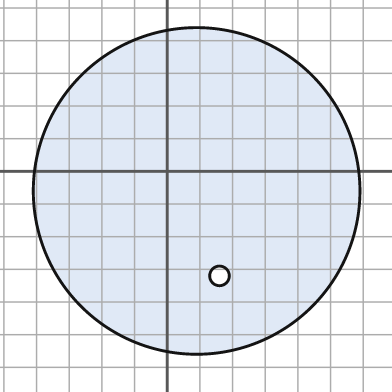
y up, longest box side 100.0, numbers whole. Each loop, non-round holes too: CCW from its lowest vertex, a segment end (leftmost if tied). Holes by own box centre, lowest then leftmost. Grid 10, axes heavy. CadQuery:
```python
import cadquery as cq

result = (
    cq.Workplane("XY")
    .moveTo(9.0, -6.0)
    .circle(50.0)
    .moveTo(16.0, -32.0)
    .circle(3.0)
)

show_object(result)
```